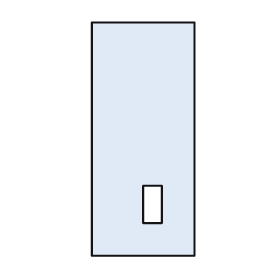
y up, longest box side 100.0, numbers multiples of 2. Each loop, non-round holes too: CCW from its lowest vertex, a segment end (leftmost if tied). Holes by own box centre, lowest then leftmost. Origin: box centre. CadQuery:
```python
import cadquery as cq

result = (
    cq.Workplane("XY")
    .moveTo(-22.0, -50.0)
    .lineTo(22.0, -50.0)
    .lineTo(22.0, 50.0)
    .lineTo(-22.0, 50.0)
    .close()
    .moveTo(0.0, -36.0)
    .lineTo(8.0, -36.0)
    .lineTo(8.0, -20.0)
    .lineTo(0.0, -20.0)
    .close()
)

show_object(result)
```